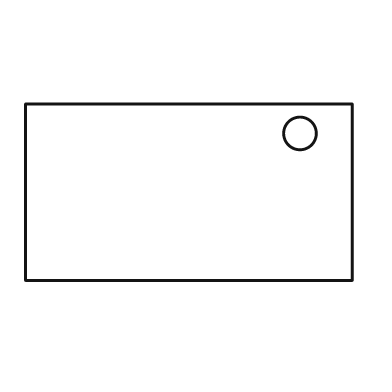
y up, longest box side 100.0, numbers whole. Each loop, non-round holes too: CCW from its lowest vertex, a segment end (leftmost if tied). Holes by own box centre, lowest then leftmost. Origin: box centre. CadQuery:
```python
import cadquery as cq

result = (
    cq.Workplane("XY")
    .moveTo(-50.0, -27.0)
    .lineTo(50.0, -27.0)
    .lineTo(50.0, 27.0)
    .lineTo(-50.0, 27.0)
    .close()
    .moveTo(34.0, 18.0)
    .circle(5.0)
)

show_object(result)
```